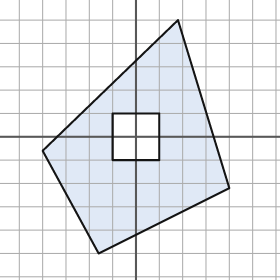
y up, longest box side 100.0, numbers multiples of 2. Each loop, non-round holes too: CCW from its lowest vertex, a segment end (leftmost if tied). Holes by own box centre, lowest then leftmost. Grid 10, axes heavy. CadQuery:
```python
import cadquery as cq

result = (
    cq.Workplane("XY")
    .moveTo(-16.0, -50.0)
    .lineTo(40.0, -22.0)
    .lineTo(18.0, 50.0)
    .lineTo(-40.0, -6.0)
    .close()
    .moveTo(-10.0, -10.0)
    .lineTo(10.0, -10.0)
    .lineTo(10.0, 10.0)
    .lineTo(-10.0, 10.0)
    .close()
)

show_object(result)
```